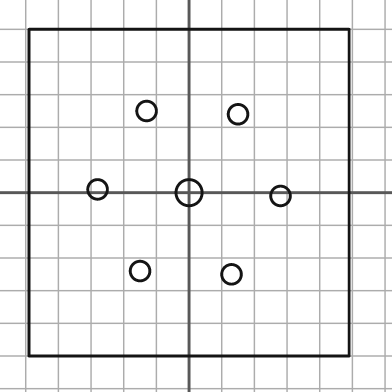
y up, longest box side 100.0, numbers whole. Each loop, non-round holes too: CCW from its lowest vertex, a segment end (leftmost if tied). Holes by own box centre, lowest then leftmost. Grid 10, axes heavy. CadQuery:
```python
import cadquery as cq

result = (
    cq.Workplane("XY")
    .moveTo(-49.0, -50.0)
    .lineTo(49.0, -50.0)
    .lineTo(49.0, 50.0)
    .lineTo(-49.0, 50.0)
    .close()
    .moveTo(13.0, -25.0)
    .circle(3.0)
    .moveTo(-15.0, -24.0)
    .circle(3.0)
    .moveTo(28.0, -1.0)
    .circle(3.0)
    .moveTo(0.0, 0.0)
    .circle(4.0)
    .moveTo(-28.0, 1.0)
    .circle(3.0)
    .moveTo(15.0, 24.0)
    .circle(3.0)
    .moveTo(-13.0, 25.0)
    .circle(3.0)
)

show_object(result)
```